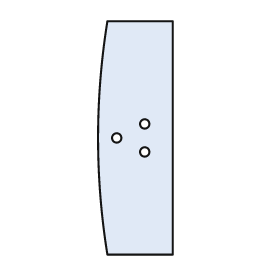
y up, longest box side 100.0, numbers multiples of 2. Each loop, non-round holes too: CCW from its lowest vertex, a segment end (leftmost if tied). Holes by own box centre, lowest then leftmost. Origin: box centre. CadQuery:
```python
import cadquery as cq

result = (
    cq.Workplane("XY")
    .moveTo(-12.0, -50.0)
    .lineTo(16.0, -50.0)
    .lineTo(16.0, 50.0)
    .lineTo(-12.0, 50.0)
    .threePointArc((-16.0, 0.0), (-12.0, -50.0))
    .close()
    .moveTo(4.0, -6.0)
    .circle(2.0)
    .moveTo(-8.0, 0.0)
    .circle(2.0)
    .moveTo(4.0, 6.0)
    .circle(2.0)
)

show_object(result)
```